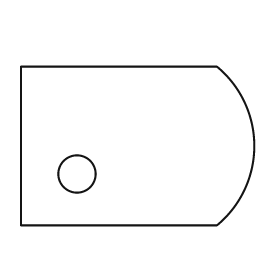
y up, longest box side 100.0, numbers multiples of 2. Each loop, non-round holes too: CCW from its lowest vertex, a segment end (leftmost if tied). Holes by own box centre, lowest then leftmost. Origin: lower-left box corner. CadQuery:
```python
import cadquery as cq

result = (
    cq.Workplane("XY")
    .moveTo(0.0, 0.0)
    .lineTo(84.0, 0.0)
    .threePointArc((100.0, 34.0), (84.0, 68.0))
    .lineTo(0.0, 68.0)
    .close()
    .moveTo(24.0, 22.0)
    .circle(8.0)
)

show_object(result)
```